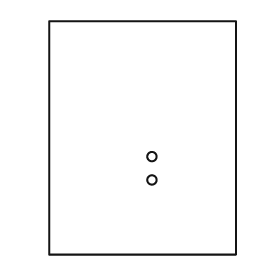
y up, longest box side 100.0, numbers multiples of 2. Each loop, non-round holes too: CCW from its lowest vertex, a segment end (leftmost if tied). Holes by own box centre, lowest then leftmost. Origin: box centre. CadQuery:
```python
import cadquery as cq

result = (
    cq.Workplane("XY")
    .moveTo(-40.0, -50.0)
    .lineTo(40.0, -50.0)
    .lineTo(40.0, 50.0)
    .lineTo(-40.0, 50.0)
    .close()
    .moveTo(4.0, -18.0)
    .circle(2.0)
    .moveTo(4.0, -8.0)
    .circle(2.0)
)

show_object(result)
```